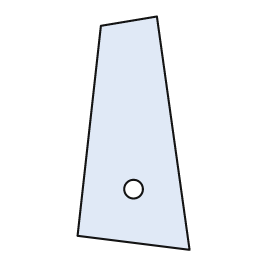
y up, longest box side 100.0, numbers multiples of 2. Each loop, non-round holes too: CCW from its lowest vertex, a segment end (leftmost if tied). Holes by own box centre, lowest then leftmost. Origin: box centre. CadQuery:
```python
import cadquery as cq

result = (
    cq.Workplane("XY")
    .moveTo(24.0, -50.0)
    .lineTo(10.0, 50.0)
    .lineTo(-14.0, 46.0)
    .lineTo(-24.0, -44.0)
    .close()
    .moveTo(0.0, -24.0)
    .circle(4.0)
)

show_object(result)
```